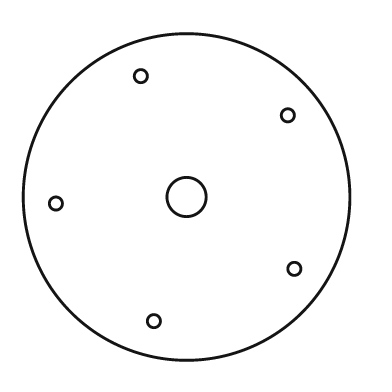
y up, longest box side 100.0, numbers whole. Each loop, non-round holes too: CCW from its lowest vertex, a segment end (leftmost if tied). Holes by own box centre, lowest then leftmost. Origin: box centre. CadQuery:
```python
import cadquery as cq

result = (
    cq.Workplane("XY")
    .moveTo(0.0, 0.0)
    .circle(50.0)
    .moveTo(-10.0, -38.0)
    .circle(2.0)
    .moveTo(33.0, -22.0)
    .circle(2.0)
    .moveTo(-40.0, -2.0)
    .circle(2.0)
    .moveTo(0.0, 0.0)
    .circle(6.0)
    .moveTo(31.0, 25.0)
    .circle(2.0)
    .moveTo(-14.0, 37.0)
    .circle(2.0)
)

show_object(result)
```